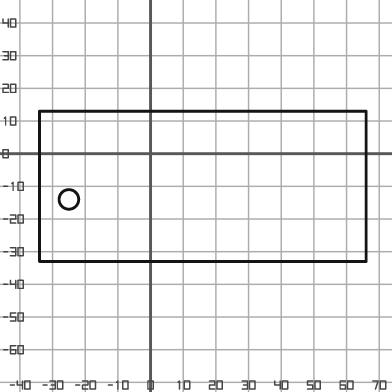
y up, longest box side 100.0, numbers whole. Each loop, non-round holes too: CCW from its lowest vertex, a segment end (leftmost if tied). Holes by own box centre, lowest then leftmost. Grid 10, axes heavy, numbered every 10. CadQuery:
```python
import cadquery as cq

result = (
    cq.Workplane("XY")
    .moveTo(-34.0, -33.0)
    .lineTo(66.0, -33.0)
    .lineTo(66.0, 13.0)
    .lineTo(-34.0, 13.0)
    .close()
    .moveTo(-25.0, -14.0)
    .circle(3.0)
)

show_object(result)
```